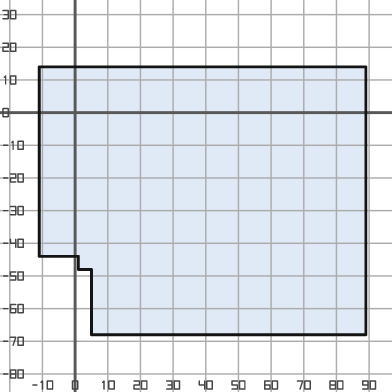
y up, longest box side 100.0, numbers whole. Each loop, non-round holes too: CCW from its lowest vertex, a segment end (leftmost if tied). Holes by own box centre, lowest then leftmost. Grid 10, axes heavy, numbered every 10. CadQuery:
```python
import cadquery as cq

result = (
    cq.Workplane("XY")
    .moveTo(5.0, -68.0)
    .lineTo(89.0, -68.0)
    .lineTo(89.0, 14.0)
    .lineTo(-11.0, 14.0)
    .lineTo(-11.0, -44.0)
    .lineTo(1.0, -44.0)
    .lineTo(1.0, -48.0)
    .lineTo(5.0, -48.0)
    .close()
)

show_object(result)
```